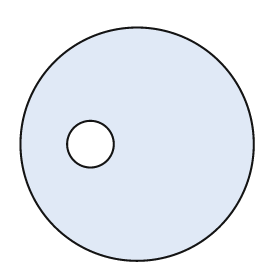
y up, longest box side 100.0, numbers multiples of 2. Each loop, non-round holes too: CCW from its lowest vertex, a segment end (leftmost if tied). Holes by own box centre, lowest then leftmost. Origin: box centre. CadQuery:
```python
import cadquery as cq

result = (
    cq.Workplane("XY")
    .moveTo(0.0, 0.0)
    .circle(50.0)
    .moveTo(-20.0, 0.0)
    .circle(10.0)
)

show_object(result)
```